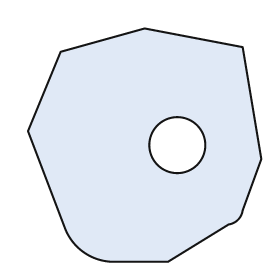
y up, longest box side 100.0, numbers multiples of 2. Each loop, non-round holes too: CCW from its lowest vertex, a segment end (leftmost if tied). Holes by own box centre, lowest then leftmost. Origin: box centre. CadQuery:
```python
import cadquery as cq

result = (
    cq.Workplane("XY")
    .moveTo(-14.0, -50.0)
    .lineTo(10.0, -50.0)
    .lineTo(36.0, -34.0)
    .threePointArc((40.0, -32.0), (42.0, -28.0))
    .lineTo(50.0, -6.0)
    .lineTo(42.0, 42.0)
    .lineTo(0.0, 50.0)
    .lineTo(-36.0, 40.0)
    .lineTo(-50.0, 6.0)
    .lineTo(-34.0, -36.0)
    .threePointArc((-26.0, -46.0), (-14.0, -50.0))
    .close()
    .moveTo(14.0, 0.0)
    .circle(12.0)
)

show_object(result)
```